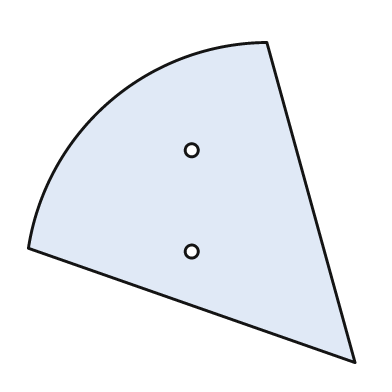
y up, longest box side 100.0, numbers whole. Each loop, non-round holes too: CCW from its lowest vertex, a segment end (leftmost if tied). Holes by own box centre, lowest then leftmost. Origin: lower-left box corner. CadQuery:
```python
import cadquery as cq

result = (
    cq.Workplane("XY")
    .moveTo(100.0, 0.0)
    .lineTo(73.0, 98.0)
    .threePointArc((25.0, 80.0), (0.0, 35.0))
    .close()
    .moveTo(50.0, 34.0)
    .circle(2.0)
    .moveTo(50.0, 65.0)
    .circle(2.0)
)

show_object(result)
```